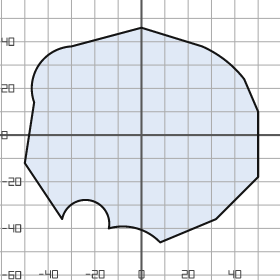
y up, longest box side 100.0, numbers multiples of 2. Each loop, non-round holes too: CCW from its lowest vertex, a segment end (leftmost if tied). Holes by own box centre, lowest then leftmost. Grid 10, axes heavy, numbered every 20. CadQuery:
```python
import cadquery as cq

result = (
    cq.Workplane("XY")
    .moveTo(8.0, -46.0)
    .lineTo(32.0, -36.0)
    .lineTo(50.0, -18.0)
    .lineTo(50.0, 10.0)
    .lineTo(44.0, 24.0)
    .threePointArc((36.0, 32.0), (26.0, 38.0))
    .lineTo(0.0, 46.0)
    .lineTo(-30.0, 38.0)
    .threePointArc((-44.0, 30.0), (-46.0, 14.0))
    .lineTo(-50.0, -12.0)
    .lineTo(-34.0, -36.0)
    .threePointArc((-22.0, -28.0), (-14.0, -40.0))
    .threePointArc((-2.0, -40.0), (8.0, -46.0))
    .close()
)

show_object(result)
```